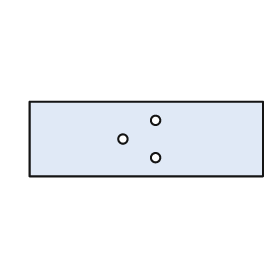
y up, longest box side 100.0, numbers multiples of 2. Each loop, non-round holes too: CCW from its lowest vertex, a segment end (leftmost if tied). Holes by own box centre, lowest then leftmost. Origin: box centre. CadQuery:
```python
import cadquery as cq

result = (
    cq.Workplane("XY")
    .moveTo(-50.0, -16.0)
    .lineTo(50.0, -16.0)
    .lineTo(50.0, 16.0)
    .lineTo(-50.0, 16.0)
    .close()
    .moveTo(4.0, -8.0)
    .circle(2.0)
    .moveTo(-10.0, 0.0)
    .circle(2.0)
    .moveTo(4.0, 8.0)
    .circle(2.0)
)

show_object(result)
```